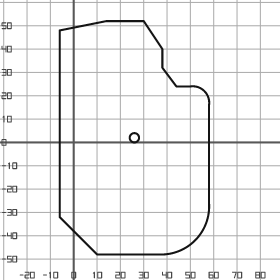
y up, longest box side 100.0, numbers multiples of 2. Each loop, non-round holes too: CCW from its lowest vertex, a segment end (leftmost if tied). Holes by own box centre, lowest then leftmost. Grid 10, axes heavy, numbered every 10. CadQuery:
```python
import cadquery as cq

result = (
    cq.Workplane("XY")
    .moveTo(10.0, -48.0)
    .lineTo(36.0, -48.0)
    .threePointArc((52.0, -42.0), (58.0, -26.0))
    .lineTo(58.0, 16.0)
    .threePointArc((56.0, 22.0), (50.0, 24.0))
    .lineTo(44.0, 24.0)
    .lineTo(38.0, 32.0)
    .lineTo(38.0, 40.0)
    .lineTo(30.0, 52.0)
    .lineTo(14.0, 52.0)
    .lineTo(-6.0, 48.0)
    .lineTo(-6.0, -32.0)
    .close()
    .moveTo(26.0, 2.0)
    .circle(2.0)
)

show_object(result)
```